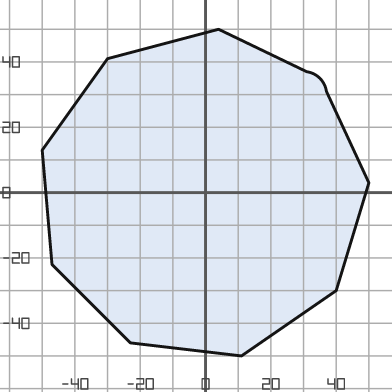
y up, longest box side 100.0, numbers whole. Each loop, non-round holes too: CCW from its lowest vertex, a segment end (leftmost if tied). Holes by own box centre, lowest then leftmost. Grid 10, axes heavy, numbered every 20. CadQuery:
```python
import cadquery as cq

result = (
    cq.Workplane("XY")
    .moveTo(11.0, -50.0)
    .lineTo(40.0, -30.0)
    .lineTo(50.0, 3.0)
    .lineTo(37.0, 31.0)
    .threePointArc((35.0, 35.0), (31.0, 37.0))
    .lineTo(4.0, 50.0)
    .lineTo(-30.0, 41.0)
    .lineTo(-50.0, 13.0)
    .lineTo(-47.0, -22.0)
    .lineTo(-23.0, -46.0)
    .close()
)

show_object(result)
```